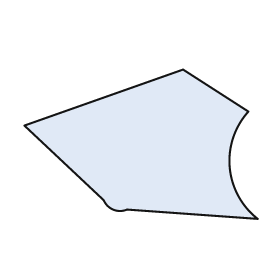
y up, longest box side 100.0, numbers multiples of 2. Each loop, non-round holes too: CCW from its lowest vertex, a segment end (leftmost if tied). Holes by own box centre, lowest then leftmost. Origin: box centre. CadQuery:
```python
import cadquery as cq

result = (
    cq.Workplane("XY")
    .moveTo(50.0, -32.0)
    .threePointArc((38.0, -10.0), (46.0, 14.0))
    .lineTo(18.0, 32.0)
    .lineTo(-50.0, 8.0)
    .lineTo(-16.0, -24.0)
    .threePointArc((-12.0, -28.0), (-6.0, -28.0))
    .close()
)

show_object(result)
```